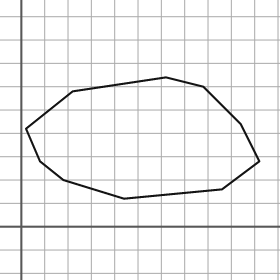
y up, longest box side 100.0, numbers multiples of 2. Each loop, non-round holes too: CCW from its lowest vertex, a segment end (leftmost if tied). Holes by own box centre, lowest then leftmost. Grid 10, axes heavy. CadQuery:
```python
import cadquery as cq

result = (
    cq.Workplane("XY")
    .moveTo(44.0, 12.0)
    .lineTo(86.0, 16.0)
    .lineTo(102.0, 28.0)
    .lineTo(94.0, 44.0)
    .lineTo(78.0, 60.0)
    .lineTo(62.0, 64.0)
    .lineTo(22.0, 58.0)
    .lineTo(2.0, 42.0)
    .lineTo(8.0, 28.0)
    .lineTo(18.0, 20.0)
    .close()
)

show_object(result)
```